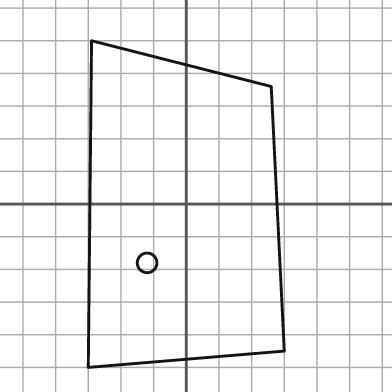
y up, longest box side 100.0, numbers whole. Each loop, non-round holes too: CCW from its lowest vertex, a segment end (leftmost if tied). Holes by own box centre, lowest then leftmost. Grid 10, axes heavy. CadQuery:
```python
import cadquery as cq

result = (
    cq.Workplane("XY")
    .moveTo(-30.0, -50.0)
    .lineTo(30.0, -45.0)
    .lineTo(26.0, 36.0)
    .lineTo(-29.0, 50.0)
    .close()
    .moveTo(-12.0, -18.0)
    .circle(3.0)
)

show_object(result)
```